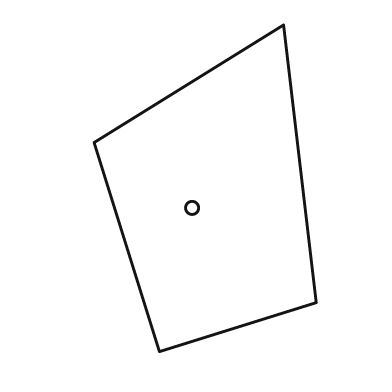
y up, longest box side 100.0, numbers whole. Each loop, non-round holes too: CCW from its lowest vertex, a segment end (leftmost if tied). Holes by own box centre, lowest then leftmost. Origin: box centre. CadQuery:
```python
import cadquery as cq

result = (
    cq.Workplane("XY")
    .moveTo(-14.0, -50.0)
    .lineTo(34.0, -35.0)
    .lineTo(24.0, 50.0)
    .lineTo(-34.0, 14.0)
    .close()
    .moveTo(-4.0, -6.0)
    .circle(2.0)
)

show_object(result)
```